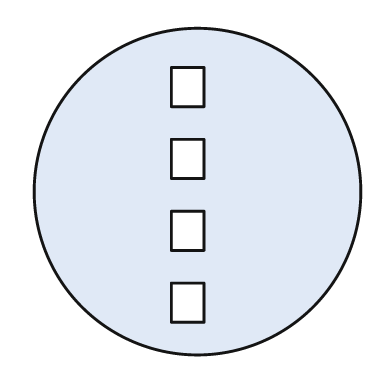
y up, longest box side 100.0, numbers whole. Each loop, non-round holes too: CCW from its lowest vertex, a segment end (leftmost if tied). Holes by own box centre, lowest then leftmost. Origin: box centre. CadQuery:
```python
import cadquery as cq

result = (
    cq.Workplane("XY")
    .moveTo(0.0, 0.0)
    .circle(50.0)
    .moveTo(-8.0, -40.0)
    .lineTo(2.0, -40.0)
    .lineTo(2.0, -28.0)
    .lineTo(-8.0, -28.0)
    .close()
    .moveTo(-8.0, -18.0)
    .lineTo(2.0, -18.0)
    .lineTo(2.0, -6.0)
    .lineTo(-8.0, -6.0)
    .close()
    .moveTo(-8.0, 4.0)
    .lineTo(2.0, 4.0)
    .lineTo(2.0, 16.0)
    .lineTo(-8.0, 16.0)
    .close()
    .moveTo(-8.0, 26.0)
    .lineTo(2.0, 26.0)
    .lineTo(2.0, 38.0)
    .lineTo(-8.0, 38.0)
    .close()
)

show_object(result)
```